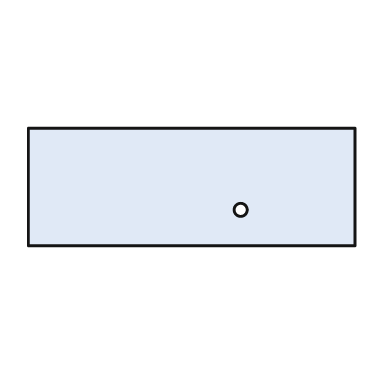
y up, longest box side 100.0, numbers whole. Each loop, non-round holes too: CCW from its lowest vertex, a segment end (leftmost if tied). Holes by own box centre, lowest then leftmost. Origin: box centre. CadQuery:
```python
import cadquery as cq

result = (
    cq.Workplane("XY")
    .moveTo(-50.0, -18.0)
    .lineTo(50.0, -18.0)
    .lineTo(50.0, 18.0)
    .lineTo(-50.0, 18.0)
    .close()
    .moveTo(15.0, -7.0)
    .circle(2.0)
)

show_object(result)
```